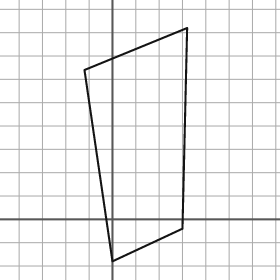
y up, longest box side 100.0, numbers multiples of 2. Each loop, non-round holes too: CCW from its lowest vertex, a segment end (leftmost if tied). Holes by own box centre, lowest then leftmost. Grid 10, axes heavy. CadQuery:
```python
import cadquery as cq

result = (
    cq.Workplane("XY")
    .moveTo(0.0, -18.0)
    .lineTo(30.0, -4.0)
    .lineTo(32.0, 82.0)
    .lineTo(-12.0, 64.0)
    .close()
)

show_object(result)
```